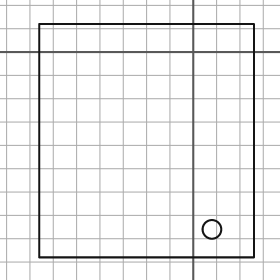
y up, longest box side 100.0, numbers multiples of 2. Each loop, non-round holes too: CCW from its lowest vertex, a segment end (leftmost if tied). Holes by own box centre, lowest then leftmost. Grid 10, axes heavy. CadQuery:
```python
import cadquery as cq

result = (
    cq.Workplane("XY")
    .moveTo(-66.0, -88.0)
    .lineTo(26.0, -88.0)
    .lineTo(26.0, 12.0)
    .lineTo(-66.0, 12.0)
    .close()
    .moveTo(8.0, -76.0)
    .circle(4.0)
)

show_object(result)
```